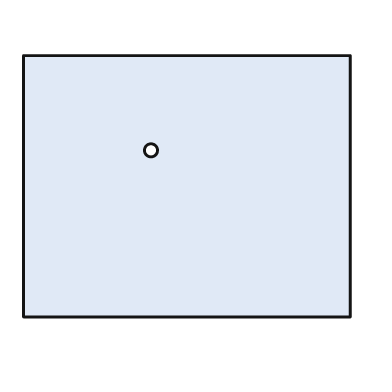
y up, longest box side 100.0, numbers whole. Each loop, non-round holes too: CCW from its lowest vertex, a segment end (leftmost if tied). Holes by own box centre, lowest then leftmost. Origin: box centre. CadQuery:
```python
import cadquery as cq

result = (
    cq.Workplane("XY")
    .moveTo(-50.0, -40.0)
    .lineTo(50.0, -40.0)
    .lineTo(50.0, 40.0)
    .lineTo(-50.0, 40.0)
    .close()
    .moveTo(-11.0, 11.0)
    .circle(2.0)
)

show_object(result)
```